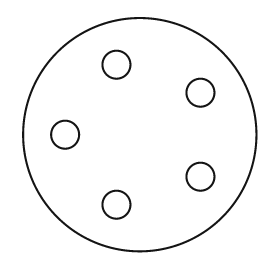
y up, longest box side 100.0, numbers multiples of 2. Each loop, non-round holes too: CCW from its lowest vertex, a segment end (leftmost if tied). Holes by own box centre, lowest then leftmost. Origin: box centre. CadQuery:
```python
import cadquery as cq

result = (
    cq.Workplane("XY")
    .moveTo(0.0, 0.0)
    .circle(50.0)
    .moveTo(-10.0, -30.0)
    .circle(6.0)
    .moveTo(26.0, -18.0)
    .circle(6.0)
    .moveTo(-32.0, 0.0)
    .circle(6.0)
    .moveTo(26.0, 18.0)
    .circle(6.0)
    .moveTo(-10.0, 30.0)
    .circle(6.0)
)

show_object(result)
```